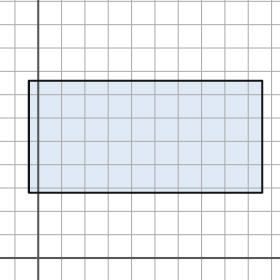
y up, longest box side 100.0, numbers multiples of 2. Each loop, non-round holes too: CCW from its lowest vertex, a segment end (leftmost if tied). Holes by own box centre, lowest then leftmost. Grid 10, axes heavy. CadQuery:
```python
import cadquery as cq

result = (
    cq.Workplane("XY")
    .moveTo(-4.0, 28.0)
    .lineTo(96.0, 28.0)
    .lineTo(96.0, 76.0)
    .lineTo(-4.0, 76.0)
    .close()
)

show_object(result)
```